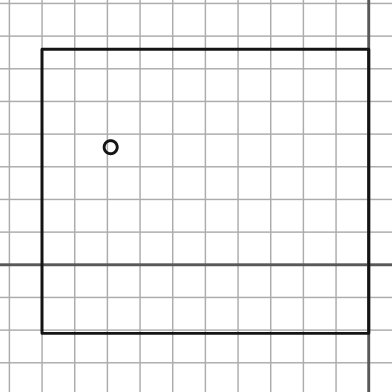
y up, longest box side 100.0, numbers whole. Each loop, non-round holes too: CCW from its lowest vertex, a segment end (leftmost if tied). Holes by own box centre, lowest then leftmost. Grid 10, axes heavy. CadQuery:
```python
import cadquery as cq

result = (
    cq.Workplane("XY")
    .moveTo(-100.0, -21.0)
    .lineTo(0.0, -21.0)
    .lineTo(0.0, 66.0)
    .lineTo(-100.0, 66.0)
    .close()
    .moveTo(-79.0, 36.0)
    .circle(2.0)
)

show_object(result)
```